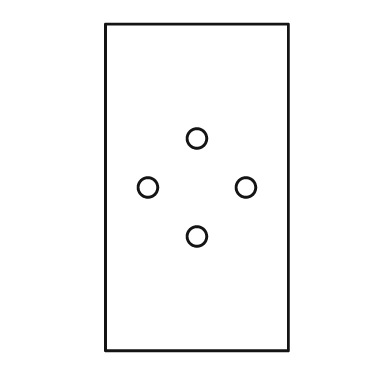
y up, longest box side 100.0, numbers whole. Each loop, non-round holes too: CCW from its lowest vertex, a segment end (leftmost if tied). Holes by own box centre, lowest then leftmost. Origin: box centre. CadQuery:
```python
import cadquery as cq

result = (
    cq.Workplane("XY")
    .moveTo(-28.0, -50.0)
    .lineTo(28.0, -50.0)
    .lineTo(28.0, 50.0)
    .lineTo(-28.0, 50.0)
    .close()
    .moveTo(0.0, -15.0)
    .circle(3.0)
    .moveTo(-15.0, 0.0)
    .circle(3.0)
    .moveTo(15.0, 0.0)
    .circle(3.0)
    .moveTo(0.0, 15.0)
    .circle(3.0)
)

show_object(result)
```